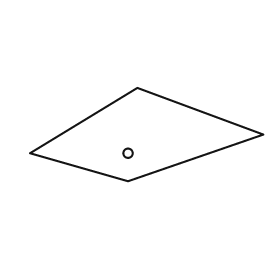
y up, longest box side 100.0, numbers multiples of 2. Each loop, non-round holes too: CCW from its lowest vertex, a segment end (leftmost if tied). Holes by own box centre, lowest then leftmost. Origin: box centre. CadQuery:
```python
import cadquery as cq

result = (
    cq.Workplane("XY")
    .moveTo(-8.0, -20.0)
    .lineTo(50.0, 0.0)
    .lineTo(-4.0, 20.0)
    .lineTo(-50.0, -8.0)
    .close()
    .moveTo(-8.0, -8.0)
    .circle(2.0)
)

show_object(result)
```